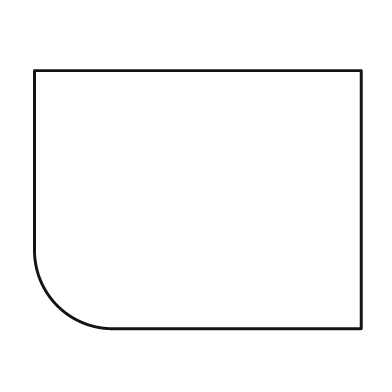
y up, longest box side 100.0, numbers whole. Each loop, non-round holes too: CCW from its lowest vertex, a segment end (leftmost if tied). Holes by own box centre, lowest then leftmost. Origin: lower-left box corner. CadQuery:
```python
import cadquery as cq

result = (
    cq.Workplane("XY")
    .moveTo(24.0, 0.0)
    .lineTo(100.0, 0.0)
    .lineTo(100.0, 79.0)
    .lineTo(0.0, 79.0)
    .lineTo(0.0, 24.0)
    .threePointArc((7.0, 7.0), (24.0, 0.0))
    .close()
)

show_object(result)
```